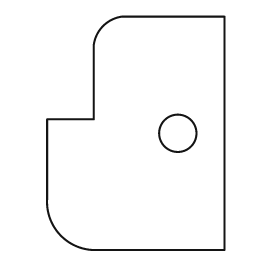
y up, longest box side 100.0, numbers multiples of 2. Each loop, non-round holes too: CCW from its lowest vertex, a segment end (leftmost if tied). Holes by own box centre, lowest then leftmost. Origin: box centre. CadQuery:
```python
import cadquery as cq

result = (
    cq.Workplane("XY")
    .moveTo(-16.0, -50.0)
    .lineTo(38.0, -50.0)
    .lineTo(38.0, 50.0)
    .lineTo(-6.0, 50.0)
    .threePointArc((-14.0, 46.0), (-18.0, 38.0))
    .lineTo(-18.0, 6.0)
    .lineTo(-38.0, 6.0)
    .lineTo(-38.0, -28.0)
    .threePointArc((-32.0, -44.0), (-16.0, -50.0))
    .close()
    .moveTo(18.0, 0.0)
    .circle(8.0)
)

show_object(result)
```